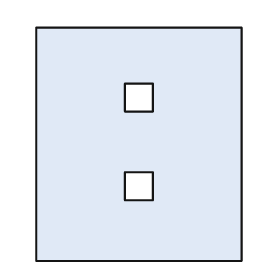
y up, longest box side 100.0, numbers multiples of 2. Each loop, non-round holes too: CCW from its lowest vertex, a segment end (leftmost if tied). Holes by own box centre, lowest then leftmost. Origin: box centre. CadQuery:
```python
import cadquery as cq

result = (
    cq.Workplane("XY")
    .moveTo(-44.0, -50.0)
    .lineTo(44.0, -50.0)
    .lineTo(44.0, 50.0)
    .lineTo(-44.0, 50.0)
    .close()
    .moveTo(-6.0, -24.0)
    .lineTo(6.0, -24.0)
    .lineTo(6.0, -12.0)
    .lineTo(-6.0, -12.0)
    .close()
    .moveTo(-6.0, 14.0)
    .lineTo(6.0, 14.0)
    .lineTo(6.0, 26.0)
    .lineTo(-6.0, 26.0)
    .close()
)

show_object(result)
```